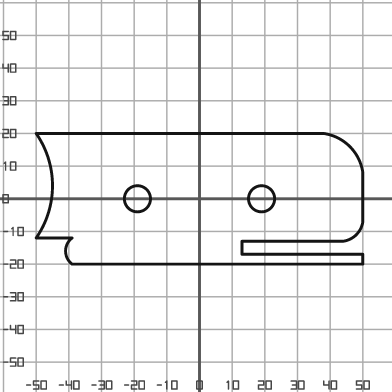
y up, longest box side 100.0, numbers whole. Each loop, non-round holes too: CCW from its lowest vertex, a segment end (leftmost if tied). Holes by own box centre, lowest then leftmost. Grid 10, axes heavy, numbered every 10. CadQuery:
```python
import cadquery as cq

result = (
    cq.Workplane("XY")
    .moveTo(-39.0, -20.0)
    .lineTo(50.0, -20.0)
    .lineTo(50.0, -17.0)
    .lineTo(13.0, -17.0)
    .lineTo(13.0, -13.0)
    .lineTo(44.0, -13.0)
    .threePointArc((48.0, -11.0), (50.0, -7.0))
    .lineTo(50.0, 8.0)
    .threePointArc((46.0, 16.0), (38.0, 20.0))
    .lineTo(-50.0, 20.0)
    .threePointArc((-45.0, 4.0), (-50.0, -12.0))
    .lineTo(-39.0, -12.0)
    .threePointArc((-41.0, -16.0), (-39.0, -20.0))
    .close()
    .moveTo(-19.0, 0.0)
    .circle(4.0)
    .moveTo(19.0, 0.0)
    .circle(4.0)
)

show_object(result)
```